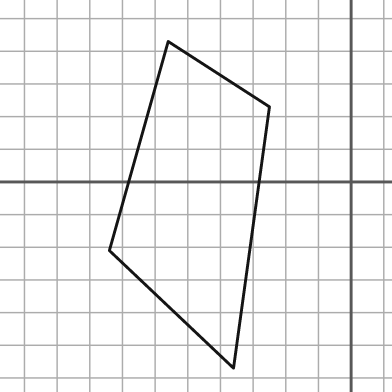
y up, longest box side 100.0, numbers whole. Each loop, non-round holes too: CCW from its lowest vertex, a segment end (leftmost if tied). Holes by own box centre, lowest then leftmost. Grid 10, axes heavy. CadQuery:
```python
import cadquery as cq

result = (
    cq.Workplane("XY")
    .moveTo(-36.0, -57.0)
    .lineTo(-25.0, 23.0)
    .lineTo(-56.0, 43.0)
    .lineTo(-74.0, -21.0)
    .close()
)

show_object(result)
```